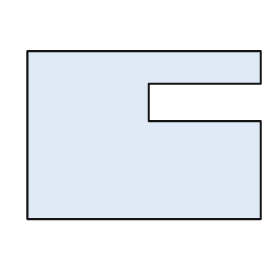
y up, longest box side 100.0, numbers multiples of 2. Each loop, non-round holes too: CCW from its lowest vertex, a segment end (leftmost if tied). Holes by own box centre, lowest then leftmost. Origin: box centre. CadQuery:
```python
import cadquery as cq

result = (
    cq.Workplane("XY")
    .moveTo(-50.0, -36.0)
    .lineTo(50.0, -36.0)
    .lineTo(50.0, 6.0)
    .lineTo(2.0, 6.0)
    .lineTo(2.0, 22.0)
    .lineTo(50.0, 22.0)
    .lineTo(50.0, 36.0)
    .lineTo(-50.0, 36.0)
    .close()
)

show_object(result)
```